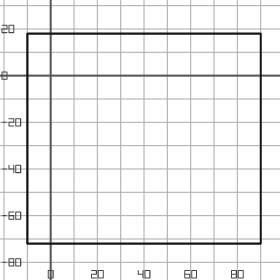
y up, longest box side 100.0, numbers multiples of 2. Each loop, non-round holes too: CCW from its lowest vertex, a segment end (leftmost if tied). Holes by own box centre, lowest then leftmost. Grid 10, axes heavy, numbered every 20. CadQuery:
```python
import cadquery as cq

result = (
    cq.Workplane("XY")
    .moveTo(-10.0, -72.0)
    .lineTo(90.0, -72.0)
    .lineTo(90.0, 18.0)
    .lineTo(-10.0, 18.0)
    .close()
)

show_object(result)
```